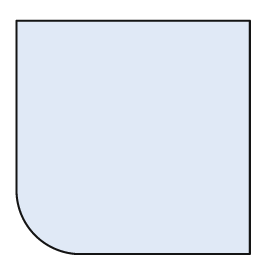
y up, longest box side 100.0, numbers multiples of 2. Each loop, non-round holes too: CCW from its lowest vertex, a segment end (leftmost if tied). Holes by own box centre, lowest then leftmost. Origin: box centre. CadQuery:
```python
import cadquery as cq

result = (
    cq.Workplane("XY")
    .moveTo(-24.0, -50.0)
    .lineTo(50.0, -50.0)
    .lineTo(50.0, 50.0)
    .lineTo(-50.0, 50.0)
    .lineTo(-50.0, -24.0)
    .threePointArc((-42.0, -42.0), (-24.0, -50.0))
    .close()
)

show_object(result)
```